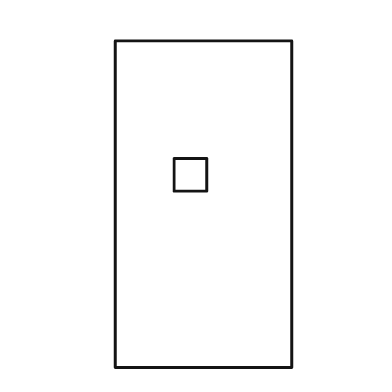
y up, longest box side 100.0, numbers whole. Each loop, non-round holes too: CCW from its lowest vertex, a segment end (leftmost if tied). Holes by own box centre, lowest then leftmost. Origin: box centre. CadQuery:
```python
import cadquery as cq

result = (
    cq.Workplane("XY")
    .moveTo(-27.0, -50.0)
    .lineTo(27.0, -50.0)
    .lineTo(27.0, 50.0)
    .lineTo(-27.0, 50.0)
    .close()
    .moveTo(-9.0, 4.0)
    .lineTo(1.0, 4.0)
    .lineTo(1.0, 14.0)
    .lineTo(-9.0, 14.0)
    .close()
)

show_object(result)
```